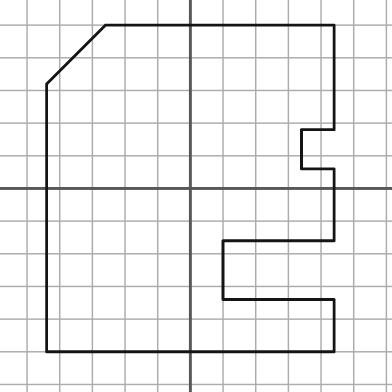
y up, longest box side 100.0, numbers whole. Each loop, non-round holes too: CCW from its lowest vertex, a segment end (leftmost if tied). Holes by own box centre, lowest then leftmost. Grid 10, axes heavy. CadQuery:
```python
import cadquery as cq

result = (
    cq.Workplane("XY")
    .moveTo(-44.0, -50.0)
    .lineTo(44.0, -50.0)
    .lineTo(44.0, -34.0)
    .lineTo(10.0, -34.0)
    .lineTo(10.0, -16.0)
    .lineTo(44.0, -16.0)
    .lineTo(44.0, 6.0)
    .lineTo(34.0, 6.0)
    .lineTo(34.0, 18.0)
    .lineTo(44.0, 18.0)
    .lineTo(44.0, 50.0)
    .lineTo(-26.0, 50.0)
    .lineTo(-44.0, 32.0)
    .close()
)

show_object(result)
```